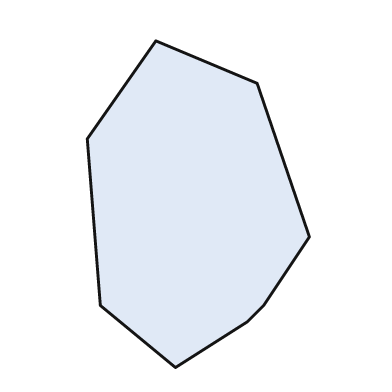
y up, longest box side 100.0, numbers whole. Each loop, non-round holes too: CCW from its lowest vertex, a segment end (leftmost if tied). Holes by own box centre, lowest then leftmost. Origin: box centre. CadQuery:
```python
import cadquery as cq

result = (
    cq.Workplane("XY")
    .moveTo(-7.0, -50.0)
    .lineTo(15.0, -36.0)
    .lineTo(20.0, -31.0)
    .lineTo(34.0, -10.0)
    .lineTo(18.0, 37.0)
    .lineTo(-13.0, 50.0)
    .lineTo(-34.0, 20.0)
    .lineTo(-30.0, -31.0)
    .close()
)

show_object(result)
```